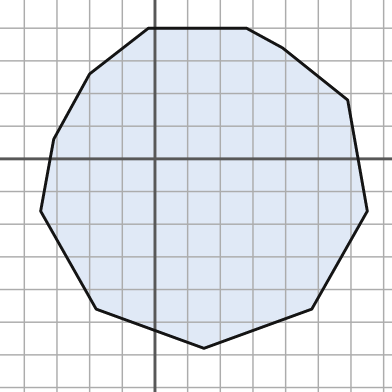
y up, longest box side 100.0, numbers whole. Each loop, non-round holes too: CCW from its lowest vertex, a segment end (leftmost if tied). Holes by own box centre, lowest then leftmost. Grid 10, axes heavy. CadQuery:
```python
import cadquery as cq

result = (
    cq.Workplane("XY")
    .moveTo(15.0, -58.0)
    .lineTo(48.0, -46.0)
    .lineTo(65.0, -16.0)
    .lineTo(59.0, 18.0)
    .lineTo(39.0, 34.0)
    .lineTo(28.0, 40.0)
    .lineTo(-2.0, 40.0)
    .lineTo(-20.0, 26.0)
    .lineTo(-31.0, 6.0)
    .lineTo(-35.0, -16.0)
    .lineTo(-18.0, -46.0)
    .close()
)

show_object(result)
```